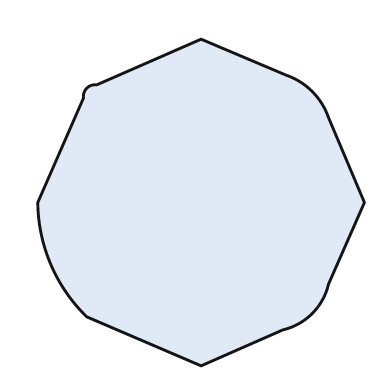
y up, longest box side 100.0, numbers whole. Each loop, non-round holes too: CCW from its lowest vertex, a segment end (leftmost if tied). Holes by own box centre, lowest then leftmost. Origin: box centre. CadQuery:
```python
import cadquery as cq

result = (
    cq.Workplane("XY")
    .moveTo(0.0, -50.0)
    .lineTo(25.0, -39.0)
    .threePointArc((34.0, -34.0), (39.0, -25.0))
    .lineTo(50.0, 0.0)
    .lineTo(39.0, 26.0)
    .threePointArc((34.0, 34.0), (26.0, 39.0))
    .lineTo(0.0, 50.0)
    .lineTo(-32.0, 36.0)
    .threePointArc((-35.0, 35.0), (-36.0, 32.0))
    .lineTo(-50.0, 0.0)
    .threePointArc((-46.0, -19.0), (-35.0, -35.0))
    .close()
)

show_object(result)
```